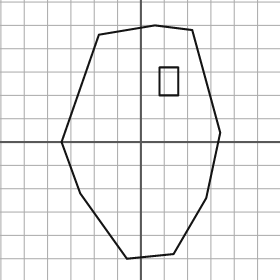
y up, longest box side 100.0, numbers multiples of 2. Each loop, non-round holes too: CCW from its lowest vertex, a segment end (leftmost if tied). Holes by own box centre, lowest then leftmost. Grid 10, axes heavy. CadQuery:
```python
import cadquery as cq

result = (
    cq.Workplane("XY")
    .moveTo(-6.0, -50.0)
    .lineTo(14.0, -48.0)
    .lineTo(28.0, -24.0)
    .lineTo(34.0, 4.0)
    .lineTo(22.0, 48.0)
    .lineTo(6.0, 50.0)
    .lineTo(-18.0, 46.0)
    .lineTo(-34.0, 0.0)
    .lineTo(-26.0, -22.0)
    .close()
    .moveTo(8.0, 20.0)
    .lineTo(16.0, 20.0)
    .lineTo(16.0, 32.0)
    .lineTo(8.0, 32.0)
    .close()
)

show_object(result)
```